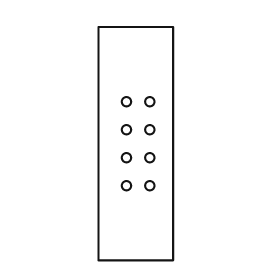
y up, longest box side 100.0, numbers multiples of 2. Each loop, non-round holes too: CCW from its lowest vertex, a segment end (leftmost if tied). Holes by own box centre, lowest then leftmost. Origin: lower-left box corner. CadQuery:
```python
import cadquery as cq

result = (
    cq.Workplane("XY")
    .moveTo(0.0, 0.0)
    .lineTo(32.0, 0.0)
    .lineTo(32.0, 100.0)
    .lineTo(0.0, 100.0)
    .close()
    .moveTo(12.0, 32.0)
    .circle(2.0)
    .moveTo(22.0, 32.0)
    .circle(2.0)
    .moveTo(12.0, 44.0)
    .circle(2.0)
    .moveTo(22.0, 44.0)
    .circle(2.0)
    .moveTo(12.0, 56.0)
    .circle(2.0)
    .moveTo(22.0, 56.0)
    .circle(2.0)
    .moveTo(12.0, 68.0)
    .circle(2.0)
    .moveTo(22.0, 68.0)
    .circle(2.0)
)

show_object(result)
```